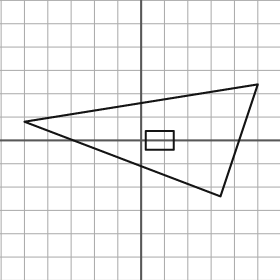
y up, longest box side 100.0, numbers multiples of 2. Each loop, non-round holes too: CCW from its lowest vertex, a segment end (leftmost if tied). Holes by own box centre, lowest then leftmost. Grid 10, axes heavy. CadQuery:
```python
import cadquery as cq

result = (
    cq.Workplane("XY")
    .moveTo(34.0, -24.0)
    .lineTo(50.0, 24.0)
    .lineTo(-50.0, 8.0)
    .close()
    .moveTo(2.0, -4.0)
    .lineTo(14.0, -4.0)
    .lineTo(14.0, 4.0)
    .lineTo(2.0, 4.0)
    .close()
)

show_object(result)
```